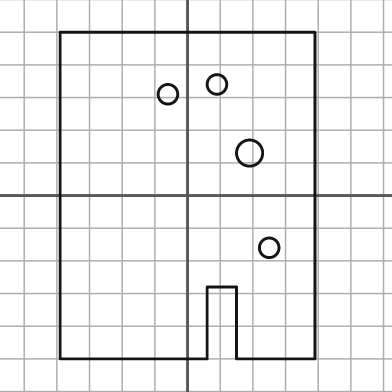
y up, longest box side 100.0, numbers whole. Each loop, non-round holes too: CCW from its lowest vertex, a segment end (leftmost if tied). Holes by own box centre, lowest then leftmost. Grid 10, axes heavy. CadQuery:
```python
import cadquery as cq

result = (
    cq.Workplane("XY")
    .moveTo(-39.0, -50.0)
    .lineTo(6.0, -50.0)
    .lineTo(6.0, -28.0)
    .lineTo(15.0, -28.0)
    .lineTo(15.0, -50.0)
    .lineTo(39.0, -50.0)
    .lineTo(39.0, 50.0)
    .lineTo(-39.0, 50.0)
    .close()
    .moveTo(25.0, -16.0)
    .circle(3.0)
    .moveTo(19.0, 13.0)
    .circle(4.0)
    .moveTo(-6.0, 31.0)
    .circle(3.0)
    .moveTo(9.0, 34.0)
    .circle(3.0)
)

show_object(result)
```